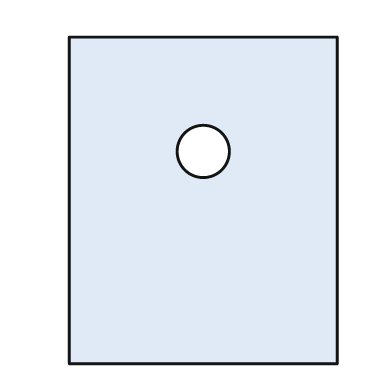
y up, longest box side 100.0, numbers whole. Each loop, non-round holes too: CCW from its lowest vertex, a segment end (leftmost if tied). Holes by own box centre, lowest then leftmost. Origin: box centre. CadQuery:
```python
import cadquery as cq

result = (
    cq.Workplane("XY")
    .moveTo(-41.0, -50.0)
    .lineTo(41.0, -50.0)
    .lineTo(41.0, 50.0)
    .lineTo(-41.0, 50.0)
    .close()
    .moveTo(0.0, 15.0)
    .circle(8.0)
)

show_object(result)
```